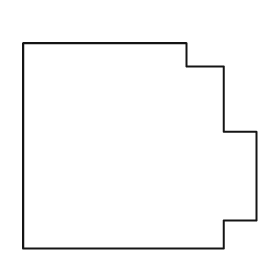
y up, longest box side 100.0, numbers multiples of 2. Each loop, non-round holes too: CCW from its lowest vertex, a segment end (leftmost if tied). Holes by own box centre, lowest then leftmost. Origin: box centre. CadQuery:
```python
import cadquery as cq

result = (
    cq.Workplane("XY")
    .moveTo(-50.0, -44.0)
    .lineTo(36.0, -44.0)
    .lineTo(36.0, -32.0)
    .lineTo(50.0, -32.0)
    .lineTo(50.0, 6.0)
    .lineTo(36.0, 6.0)
    .lineTo(36.0, 34.0)
    .lineTo(20.0, 34.0)
    .lineTo(20.0, 44.0)
    .lineTo(-50.0, 44.0)
    .close()
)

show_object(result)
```